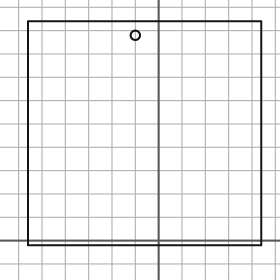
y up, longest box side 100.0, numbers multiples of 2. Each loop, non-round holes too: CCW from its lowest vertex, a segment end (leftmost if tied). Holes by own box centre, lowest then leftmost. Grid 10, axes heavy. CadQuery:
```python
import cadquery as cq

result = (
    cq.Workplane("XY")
    .moveTo(-56.0, -2.0)
    .lineTo(44.0, -2.0)
    .lineTo(44.0, 94.0)
    .lineTo(-56.0, 94.0)
    .close()
    .moveTo(-10.0, 88.0)
    .circle(2.0)
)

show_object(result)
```